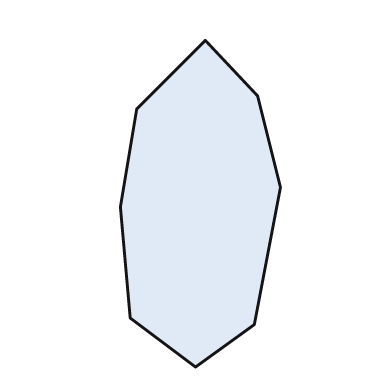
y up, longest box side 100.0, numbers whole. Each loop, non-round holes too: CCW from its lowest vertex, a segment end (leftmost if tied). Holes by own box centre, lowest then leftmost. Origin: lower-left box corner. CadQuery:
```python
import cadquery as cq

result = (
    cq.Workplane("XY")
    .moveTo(23.0, 0.0)
    .lineTo(41.0, 13.0)
    .lineTo(49.0, 55.0)
    .lineTo(42.0, 83.0)
    .lineTo(26.0, 100.0)
    .lineTo(5.0, 79.0)
    .lineTo(0.0, 49.0)
    .lineTo(3.0, 15.0)
    .close()
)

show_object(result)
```